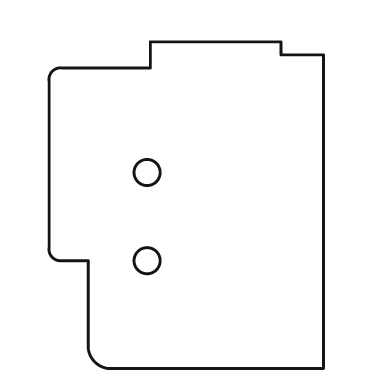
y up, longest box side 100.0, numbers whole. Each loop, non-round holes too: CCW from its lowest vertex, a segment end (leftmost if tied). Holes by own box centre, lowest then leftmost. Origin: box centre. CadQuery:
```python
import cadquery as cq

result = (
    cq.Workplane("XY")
    .moveTo(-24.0, -50.0)
    .lineTo(42.0, -50.0)
    .lineTo(42.0, 46.0)
    .lineTo(29.0, 46.0)
    .lineTo(29.0, 50.0)
    .lineTo(-11.0, 50.0)
    .lineTo(-11.0, 42.0)
    .lineTo(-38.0, 42.0)
    .threePointArc((-41.0, 41.0), (-42.0, 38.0))
    .lineTo(-42.0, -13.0)
    .threePointArc((-41.0, -16.0), (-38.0, -17.0))
    .lineTo(-30.0, -17.0)
    .lineTo(-30.0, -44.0)
    .threePointArc((-28.0, -48.0), (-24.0, -50.0))
    .close()
    .moveTo(-12.0, -17.0)
    .circle(4.0)
    .moveTo(-12.0, 10.0)
    .circle(4.0)
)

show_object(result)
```